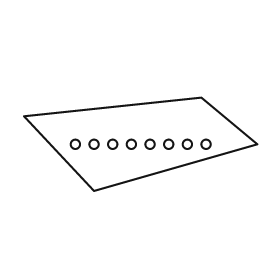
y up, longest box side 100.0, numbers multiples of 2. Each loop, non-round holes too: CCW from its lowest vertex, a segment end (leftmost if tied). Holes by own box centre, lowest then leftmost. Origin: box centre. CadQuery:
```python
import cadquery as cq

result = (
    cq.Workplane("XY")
    .moveTo(-20.0, -20.0)
    .lineTo(50.0, 0.0)
    .lineTo(26.0, 20.0)
    .lineTo(-50.0, 12.0)
    .close()
    .moveTo(-28.0, 0.0)
    .circle(2.0)
    .moveTo(-20.0, 0.0)
    .circle(2.0)
    .moveTo(-12.0, 0.0)
    .circle(2.0)
    .moveTo(-4.0, 0.0)
    .circle(2.0)
    .moveTo(4.0, 0.0)
    .circle(2.0)
    .moveTo(12.0, 0.0)
    .circle(2.0)
    .moveTo(20.0, 0.0)
    .circle(2.0)
    .moveTo(28.0, 0.0)
    .circle(2.0)
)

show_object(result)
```